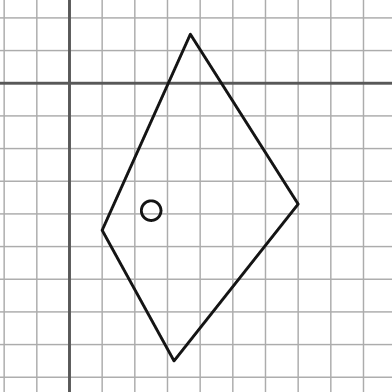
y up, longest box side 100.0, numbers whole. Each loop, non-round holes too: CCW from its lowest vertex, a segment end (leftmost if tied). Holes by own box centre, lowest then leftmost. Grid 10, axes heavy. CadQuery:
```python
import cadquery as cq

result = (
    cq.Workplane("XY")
    .moveTo(32.0, -85.0)
    .lineTo(70.0, -37.0)
    .lineTo(37.0, 15.0)
    .lineTo(10.0, -45.0)
    .close()
    .moveTo(25.0, -39.0)
    .circle(3.0)
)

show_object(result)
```